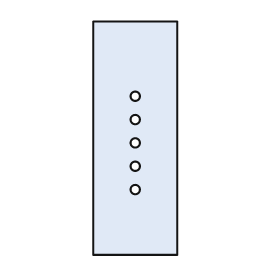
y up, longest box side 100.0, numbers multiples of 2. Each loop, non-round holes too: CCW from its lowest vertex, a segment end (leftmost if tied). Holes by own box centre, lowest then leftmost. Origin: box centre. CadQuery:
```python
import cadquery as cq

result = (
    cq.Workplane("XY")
    .moveTo(-18.0, -50.0)
    .lineTo(18.0, -50.0)
    .lineTo(18.0, 50.0)
    .lineTo(-18.0, 50.0)
    .close()
    .moveTo(0.0, -22.0)
    .circle(2.0)
    .moveTo(0.0, -12.0)
    .circle(2.0)
    .moveTo(0.0, -2.0)
    .circle(2.0)
    .moveTo(0.0, 8.0)
    .circle(2.0)
    .moveTo(0.0, 18.0)
    .circle(2.0)
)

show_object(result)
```